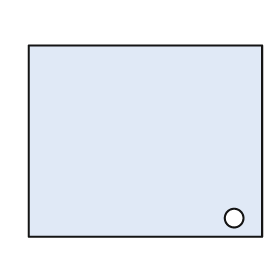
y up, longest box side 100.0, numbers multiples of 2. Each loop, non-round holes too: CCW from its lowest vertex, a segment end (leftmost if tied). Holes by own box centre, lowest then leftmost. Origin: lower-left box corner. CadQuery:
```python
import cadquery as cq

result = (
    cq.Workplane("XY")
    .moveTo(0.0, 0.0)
    .lineTo(100.0, 0.0)
    .lineTo(100.0, 82.0)
    .lineTo(0.0, 82.0)
    .close()
    .moveTo(88.0, 8.0)
    .circle(4.0)
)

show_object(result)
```